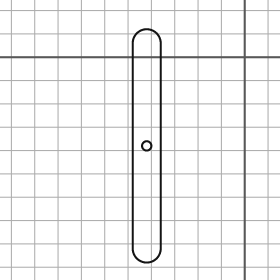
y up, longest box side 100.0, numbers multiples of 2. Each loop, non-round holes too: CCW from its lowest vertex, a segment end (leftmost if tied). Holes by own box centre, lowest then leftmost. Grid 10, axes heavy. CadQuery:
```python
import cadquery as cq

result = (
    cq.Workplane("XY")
    .moveTo(-48.0, -82.0)
    .threePointArc((-42.0, -88.0), (-36.0, -82.0))
    .lineTo(-36.0, 6.0)
    .threePointArc((-42.0, 12.0), (-48.0, 6.0))
    .close()
    .moveTo(-42.0, -38.0)
    .circle(2.0)
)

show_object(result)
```